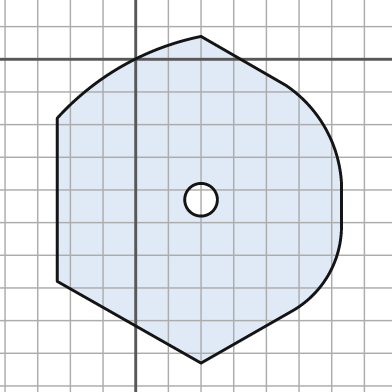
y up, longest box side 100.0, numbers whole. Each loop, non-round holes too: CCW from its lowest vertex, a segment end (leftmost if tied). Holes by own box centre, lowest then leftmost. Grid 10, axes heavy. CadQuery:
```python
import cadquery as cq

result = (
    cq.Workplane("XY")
    .moveTo(20.0, -93.0)
    .lineTo(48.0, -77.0)
    .threePointArc((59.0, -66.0), (63.0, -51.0))
    .lineTo(63.0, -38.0)
    .threePointArc((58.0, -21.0), (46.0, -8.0))
    .lineTo(20.0, 7.0)
    .threePointArc((-4.0, -2.0), (-24.0, -18.0))
    .lineTo(-24.0, -68.0)
    .close()
    .moveTo(20.0, -43.0)
    .circle(5.0)
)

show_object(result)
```